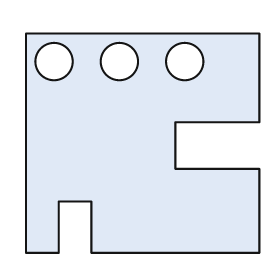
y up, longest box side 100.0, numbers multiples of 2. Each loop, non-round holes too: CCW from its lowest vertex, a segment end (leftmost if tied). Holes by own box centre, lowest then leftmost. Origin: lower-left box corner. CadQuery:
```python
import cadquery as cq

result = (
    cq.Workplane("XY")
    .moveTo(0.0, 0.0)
    .lineTo(14.0, 0.0)
    .lineTo(14.0, 22.0)
    .lineTo(28.0, 22.0)
    .lineTo(28.0, 0.0)
    .lineTo(100.0, 0.0)
    .lineTo(100.0, 36.0)
    .lineTo(64.0, 36.0)
    .lineTo(64.0, 56.0)
    .lineTo(100.0, 56.0)
    .lineTo(100.0, 94.0)
    .lineTo(0.0, 94.0)
    .close()
    .moveTo(12.0, 82.0)
    .circle(8.0)
    .moveTo(40.0, 82.0)
    .circle(8.0)
    .moveTo(68.0, 82.0)
    .circle(8.0)
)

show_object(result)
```